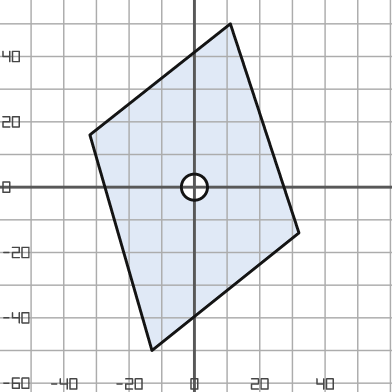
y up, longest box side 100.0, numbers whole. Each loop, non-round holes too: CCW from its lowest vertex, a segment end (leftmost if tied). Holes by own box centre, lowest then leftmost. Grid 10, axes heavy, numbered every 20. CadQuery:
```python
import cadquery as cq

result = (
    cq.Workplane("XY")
    .moveTo(-13.0, -50.0)
    .lineTo(32.0, -14.0)
    .lineTo(11.0, 50.0)
    .lineTo(-32.0, 16.0)
    .close()
    .moveTo(0.0, 0.0)
    .circle(4.0)
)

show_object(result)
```